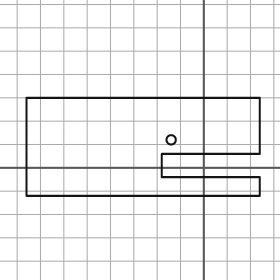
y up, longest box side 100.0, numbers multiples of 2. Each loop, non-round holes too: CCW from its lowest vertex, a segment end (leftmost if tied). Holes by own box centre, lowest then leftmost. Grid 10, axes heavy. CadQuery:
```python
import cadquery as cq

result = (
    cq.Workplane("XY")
    .moveTo(-76.0, -12.0)
    .lineTo(24.0, -12.0)
    .lineTo(24.0, -4.0)
    .lineTo(-18.0, -4.0)
    .lineTo(-18.0, 6.0)
    .lineTo(24.0, 6.0)
    .lineTo(24.0, 30.0)
    .lineTo(-76.0, 30.0)
    .close()
    .moveTo(-14.0, 12.0)
    .circle(2.0)
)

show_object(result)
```